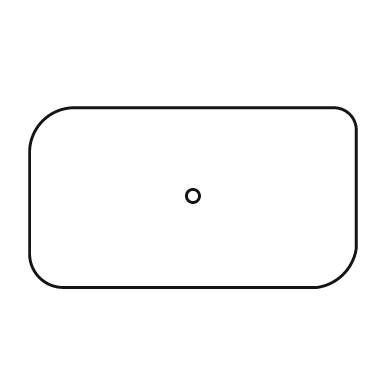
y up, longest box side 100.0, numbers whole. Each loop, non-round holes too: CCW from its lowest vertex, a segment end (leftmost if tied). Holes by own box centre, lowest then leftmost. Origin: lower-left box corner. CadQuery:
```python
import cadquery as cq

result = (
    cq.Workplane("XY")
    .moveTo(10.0, 0.0)
    .lineTo(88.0, 0.0)
    .threePointArc((96.0, 4.0), (100.0, 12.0))
    .lineTo(100.0, 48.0)
    .threePointArc((98.0, 53.0), (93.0, 55.0))
    .lineTo(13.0, 55.0)
    .threePointArc((4.0, 51.0), (0.0, 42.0))
    .lineTo(0.0, 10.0)
    .threePointArc((3.0, 3.0), (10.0, 0.0))
    .close()
    .moveTo(50.0, 28.0)
    .circle(2.0)
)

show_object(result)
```